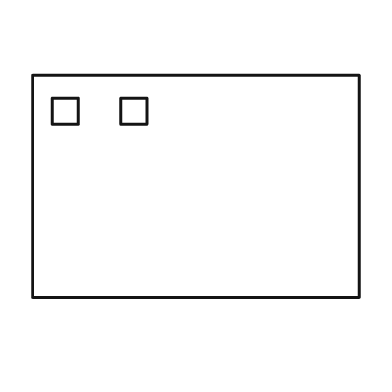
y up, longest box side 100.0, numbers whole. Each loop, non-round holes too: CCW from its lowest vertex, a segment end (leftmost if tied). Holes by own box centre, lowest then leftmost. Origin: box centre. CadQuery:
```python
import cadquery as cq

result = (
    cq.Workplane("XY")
    .moveTo(-50.0, -34.0)
    .lineTo(50.0, -34.0)
    .lineTo(50.0, 34.0)
    .lineTo(-50.0, 34.0)
    .close()
    .moveTo(-44.0, 19.0)
    .lineTo(-36.0, 19.0)
    .lineTo(-36.0, 27.0)
    .lineTo(-44.0, 27.0)
    .close()
    .moveTo(-23.0, 19.0)
    .lineTo(-15.0, 19.0)
    .lineTo(-15.0, 27.0)
    .lineTo(-23.0, 27.0)
    .close()
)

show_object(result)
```